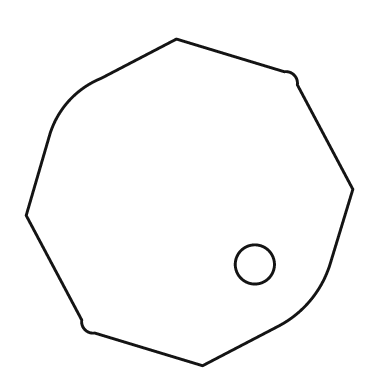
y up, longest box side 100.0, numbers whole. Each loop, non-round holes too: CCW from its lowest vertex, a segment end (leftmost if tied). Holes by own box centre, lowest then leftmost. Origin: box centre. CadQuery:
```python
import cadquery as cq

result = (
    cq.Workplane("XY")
    .moveTo(4.0, -50.0)
    .lineTo(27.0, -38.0)
    .threePointArc((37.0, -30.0), (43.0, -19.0))
    .lineTo(50.0, 4.0)
    .lineTo(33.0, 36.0)
    .threePointArc((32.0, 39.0), (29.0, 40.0))
    .lineTo(-4.0, 50.0)
    .lineTo(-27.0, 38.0)
    .threePointArc((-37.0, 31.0), (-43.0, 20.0))
    .lineTo(-50.0, -4.0)
    .lineTo(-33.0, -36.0)
    .threePointArc((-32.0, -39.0), (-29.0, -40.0))
    .close()
    .moveTo(20.0, -19.0)
    .circle(6.0)
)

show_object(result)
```